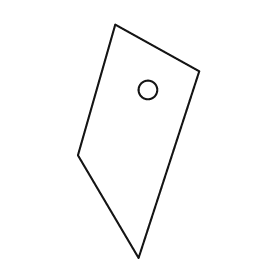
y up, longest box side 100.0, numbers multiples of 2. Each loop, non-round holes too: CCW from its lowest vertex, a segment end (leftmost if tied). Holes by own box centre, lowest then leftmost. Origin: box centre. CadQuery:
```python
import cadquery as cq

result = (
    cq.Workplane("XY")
    .moveTo(0.0, -50.0)
    .lineTo(26.0, 30.0)
    .lineTo(-10.0, 50.0)
    .lineTo(-26.0, -6.0)
    .close()
    .moveTo(4.0, 22.0)
    .circle(4.0)
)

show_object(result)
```